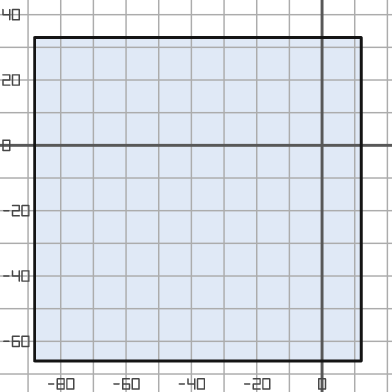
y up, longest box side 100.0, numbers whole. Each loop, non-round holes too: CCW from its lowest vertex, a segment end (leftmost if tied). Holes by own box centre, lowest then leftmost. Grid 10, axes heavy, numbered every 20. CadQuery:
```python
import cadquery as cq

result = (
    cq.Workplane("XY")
    .moveTo(-88.0, -66.0)
    .lineTo(12.0, -66.0)
    .lineTo(12.0, 33.0)
    .lineTo(-88.0, 33.0)
    .close()
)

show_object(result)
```